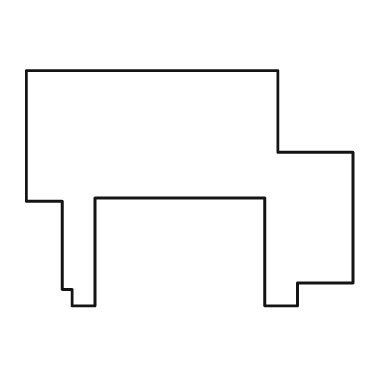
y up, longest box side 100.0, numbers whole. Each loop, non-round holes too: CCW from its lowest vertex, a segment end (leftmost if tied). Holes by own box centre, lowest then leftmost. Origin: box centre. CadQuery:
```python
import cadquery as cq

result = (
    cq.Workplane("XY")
    .moveTo(-36.0, -36.0)
    .lineTo(-29.0, -36.0)
    .lineTo(-29.0, -3.0)
    .lineTo(23.0, -3.0)
    .lineTo(23.0, -36.0)
    .lineTo(33.0, -36.0)
    .lineTo(33.0, -29.0)
    .lineTo(50.0, -29.0)
    .lineTo(50.0, 11.0)
    .lineTo(27.0, 11.0)
    .lineTo(27.0, 36.0)
    .lineTo(-50.0, 36.0)
    .lineTo(-50.0, -4.0)
    .lineTo(-39.0, -4.0)
    .lineTo(-39.0, -31.0)
    .lineTo(-36.0, -31.0)
    .close()
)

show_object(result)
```